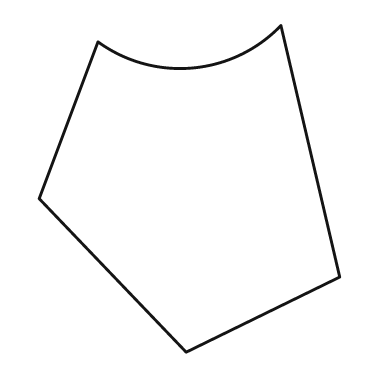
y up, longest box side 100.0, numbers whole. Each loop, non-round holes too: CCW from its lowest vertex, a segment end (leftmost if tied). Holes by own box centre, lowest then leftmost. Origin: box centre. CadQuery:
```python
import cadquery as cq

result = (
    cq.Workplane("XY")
    .moveTo(-1.0, -50.0)
    .lineTo(46.0, -27.0)
    .lineTo(28.0, 50.0)
    .threePointArc((1.0, 37.0), (-28.0, 45.0))
    .lineTo(-46.0, -3.0)
    .close()
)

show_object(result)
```